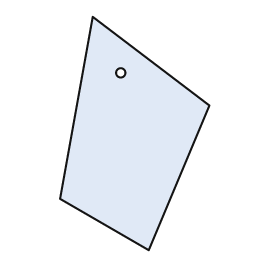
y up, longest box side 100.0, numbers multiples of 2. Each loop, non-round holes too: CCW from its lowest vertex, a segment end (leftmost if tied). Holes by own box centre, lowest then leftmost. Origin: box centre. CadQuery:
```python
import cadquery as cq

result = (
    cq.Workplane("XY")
    .moveTo(6.0, -50.0)
    .lineTo(32.0, 12.0)
    .lineTo(-18.0, 50.0)
    .lineTo(-32.0, -28.0)
    .close()
    .moveTo(-6.0, 26.0)
    .circle(2.0)
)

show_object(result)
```